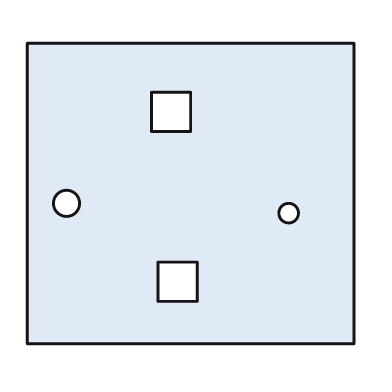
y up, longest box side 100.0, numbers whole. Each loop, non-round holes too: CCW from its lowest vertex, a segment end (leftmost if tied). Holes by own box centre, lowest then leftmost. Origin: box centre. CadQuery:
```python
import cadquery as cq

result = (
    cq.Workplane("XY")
    .moveTo(-50.0, -46.0)
    .lineTo(50.0, -46.0)
    .lineTo(50.0, 46.0)
    .lineTo(-50.0, 46.0)
    .close()
    .moveTo(-10.0, -33.0)
    .lineTo(2.0, -33.0)
    .lineTo(2.0, -21.0)
    .lineTo(-10.0, -21.0)
    .close()
    .moveTo(30.0, -6.0)
    .circle(3.0)
    .moveTo(-38.0, -3.0)
    .circle(4.0)
    .moveTo(-12.0, 19.0)
    .lineTo(0.0, 19.0)
    .lineTo(0.0, 31.0)
    .lineTo(-12.0, 31.0)
    .close()
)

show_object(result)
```